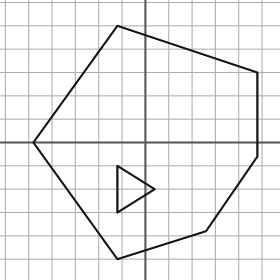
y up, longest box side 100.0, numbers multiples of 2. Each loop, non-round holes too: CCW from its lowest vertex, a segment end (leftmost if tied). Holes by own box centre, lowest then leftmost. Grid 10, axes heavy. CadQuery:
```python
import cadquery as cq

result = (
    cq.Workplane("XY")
    .moveTo(-12.0, -50.0)
    .lineTo(26.0, -38.0)
    .lineTo(48.0, -6.0)
    .lineTo(48.0, 30.0)
    .lineTo(-12.0, 50.0)
    .lineTo(-48.0, 0.0)
    .close()
    .moveTo(-12.0, -30.0)
    .lineTo(4.0, -20.0)
    .lineTo(-12.0, -10.0)
    .close()
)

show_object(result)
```